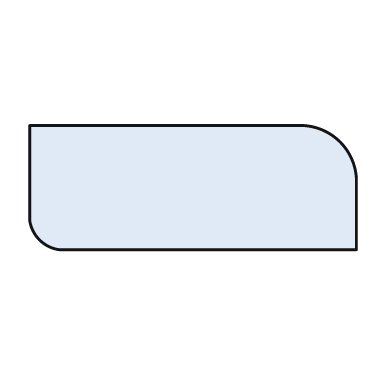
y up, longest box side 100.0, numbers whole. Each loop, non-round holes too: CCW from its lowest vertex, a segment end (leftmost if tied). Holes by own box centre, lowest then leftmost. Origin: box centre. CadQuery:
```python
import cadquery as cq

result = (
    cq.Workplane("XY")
    .moveTo(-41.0, -19.0)
    .lineTo(50.0, -19.0)
    .lineTo(50.0, 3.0)
    .threePointArc((45.0, 14.0), (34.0, 19.0))
    .lineTo(-50.0, 19.0)
    .lineTo(-50.0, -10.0)
    .threePointArc((-47.0, -16.0), (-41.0, -19.0))
    .close()
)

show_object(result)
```